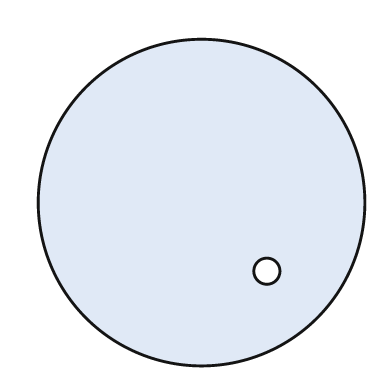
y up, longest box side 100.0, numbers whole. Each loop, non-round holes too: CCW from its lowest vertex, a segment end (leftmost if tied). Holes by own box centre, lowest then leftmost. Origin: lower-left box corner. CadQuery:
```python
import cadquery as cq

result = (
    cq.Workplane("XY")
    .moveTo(50.0, 50.0)
    .circle(50.0)
    .moveTo(70.0, 29.0)
    .circle(4.0)
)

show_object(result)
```